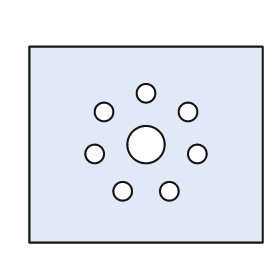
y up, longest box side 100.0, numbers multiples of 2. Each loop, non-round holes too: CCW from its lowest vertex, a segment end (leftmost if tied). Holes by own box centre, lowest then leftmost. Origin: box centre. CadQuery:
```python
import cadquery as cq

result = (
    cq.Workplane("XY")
    .moveTo(-50.0, -42.0)
    .lineTo(50.0, -42.0)
    .lineTo(50.0, 42.0)
    .lineTo(-50.0, 42.0)
    .close()
    .moveTo(-10.0, -20.0)
    .circle(4.0)
    .moveTo(10.0, -20.0)
    .circle(4.0)
    .moveTo(-22.0, -4.0)
    .circle(4.0)
    .moveTo(22.0, -4.0)
    .circle(4.0)
    .moveTo(0.0, 0.0)
    .circle(8.0)
    .moveTo(-18.0, 14.0)
    .circle(4.0)
    .moveTo(18.0, 14.0)
    .circle(4.0)
    .moveTo(0.0, 22.0)
    .circle(4.0)
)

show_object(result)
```